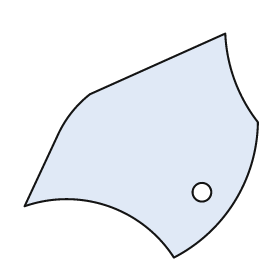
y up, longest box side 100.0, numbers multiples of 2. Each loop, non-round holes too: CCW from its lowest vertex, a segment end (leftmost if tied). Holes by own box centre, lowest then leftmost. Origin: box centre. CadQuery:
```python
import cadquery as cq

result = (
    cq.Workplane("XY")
    .moveTo(14.0, -48.0)
    .threePointArc((40.0, -24.0), (50.0, 10.0))
    .threePointArc((40.0, 28.0), (36.0, 48.0))
    .lineTo(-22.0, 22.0)
    .threePointArc((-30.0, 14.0), (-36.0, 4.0))
    .lineTo(-50.0, -26.0)
    .threePointArc((-14.0, -26.0), (14.0, -48.0))
    .close()
    .moveTo(26.0, -20.0)
    .circle(4.0)
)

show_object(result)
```